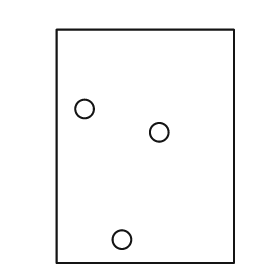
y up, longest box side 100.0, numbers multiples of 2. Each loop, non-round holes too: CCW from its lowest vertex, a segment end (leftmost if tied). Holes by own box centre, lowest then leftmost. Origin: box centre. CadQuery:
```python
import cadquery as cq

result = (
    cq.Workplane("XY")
    .moveTo(-38.0, -50.0)
    .lineTo(38.0, -50.0)
    .lineTo(38.0, 50.0)
    .lineTo(-38.0, 50.0)
    .close()
    .moveTo(-10.0, -40.0)
    .circle(4.0)
    .moveTo(6.0, 6.0)
    .circle(4.0)
    .moveTo(-26.0, 16.0)
    .circle(4.0)
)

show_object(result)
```